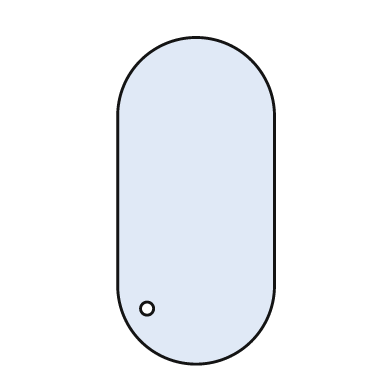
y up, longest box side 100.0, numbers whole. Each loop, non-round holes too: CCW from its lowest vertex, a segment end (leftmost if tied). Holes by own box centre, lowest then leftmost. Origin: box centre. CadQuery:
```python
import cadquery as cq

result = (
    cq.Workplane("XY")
    .moveTo(-24.0, -26.0)
    .threePointArc((0.0, -50.0), (24.0, -26.0))
    .lineTo(24.0, 26.0)
    .threePointArc((0.0, 50.0), (-24.0, 26.0))
    .close()
    .moveTo(-15.0, -33.0)
    .circle(2.0)
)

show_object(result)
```